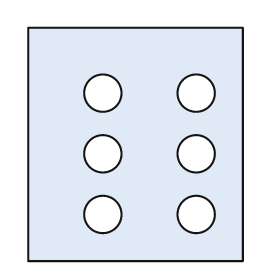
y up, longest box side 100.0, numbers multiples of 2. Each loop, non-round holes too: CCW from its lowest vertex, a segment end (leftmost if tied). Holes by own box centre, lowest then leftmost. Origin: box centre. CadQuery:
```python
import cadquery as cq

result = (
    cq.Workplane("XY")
    .moveTo(-46.0, -50.0)
    .lineTo(46.0, -50.0)
    .lineTo(46.0, 50.0)
    .lineTo(-46.0, 50.0)
    .close()
    .moveTo(-14.0, -30.0)
    .circle(8.0)
    .moveTo(26.0, -30.0)
    .circle(8.0)
    .moveTo(-14.0, -4.0)
    .circle(8.0)
    .moveTo(26.0, -4.0)
    .circle(8.0)
    .moveTo(-14.0, 22.0)
    .circle(8.0)
    .moveTo(26.0, 22.0)
    .circle(8.0)
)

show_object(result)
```